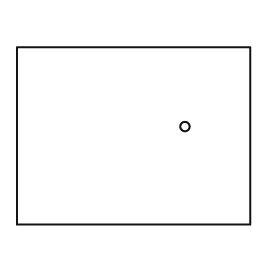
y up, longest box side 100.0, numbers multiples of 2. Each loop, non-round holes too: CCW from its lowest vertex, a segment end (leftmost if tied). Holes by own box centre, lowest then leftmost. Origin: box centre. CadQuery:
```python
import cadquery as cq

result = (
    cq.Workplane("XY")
    .moveTo(-50.0, -38.0)
    .lineTo(50.0, -38.0)
    .lineTo(50.0, 38.0)
    .lineTo(-50.0, 38.0)
    .close()
    .moveTo(22.0, 4.0)
    .circle(2.0)
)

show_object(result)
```